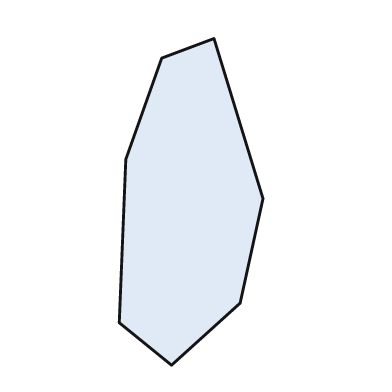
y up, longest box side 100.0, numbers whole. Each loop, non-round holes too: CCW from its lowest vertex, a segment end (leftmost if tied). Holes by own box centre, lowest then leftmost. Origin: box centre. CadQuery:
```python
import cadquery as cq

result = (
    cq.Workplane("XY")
    .moveTo(-6.0, -50.0)
    .lineTo(15.0, -31.0)
    .lineTo(22.0, 1.0)
    .lineTo(7.0, 50.0)
    .lineTo(-9.0, 44.0)
    .lineTo(-20.0, 13.0)
    .lineTo(-22.0, -37.0)
    .close()
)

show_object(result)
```